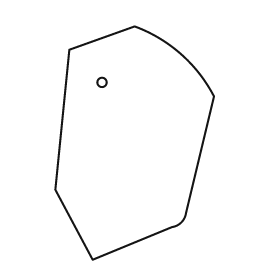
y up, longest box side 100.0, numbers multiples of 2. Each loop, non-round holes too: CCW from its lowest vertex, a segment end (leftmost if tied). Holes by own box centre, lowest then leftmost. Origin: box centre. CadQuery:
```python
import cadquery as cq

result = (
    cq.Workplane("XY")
    .moveTo(-18.0, -50.0)
    .lineTo(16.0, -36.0)
    .threePointArc((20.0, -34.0), (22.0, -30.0))
    .lineTo(34.0, 20.0)
    .threePointArc((20.0, 38.0), (0.0, 50.0))
    .lineTo(-28.0, 40.0)
    .lineTo(-34.0, -20.0)
    .close()
    .moveTo(-14.0, 26.0)
    .circle(2.0)
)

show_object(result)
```